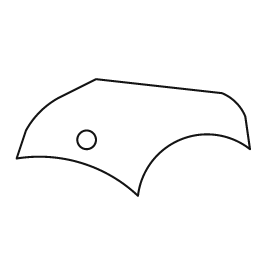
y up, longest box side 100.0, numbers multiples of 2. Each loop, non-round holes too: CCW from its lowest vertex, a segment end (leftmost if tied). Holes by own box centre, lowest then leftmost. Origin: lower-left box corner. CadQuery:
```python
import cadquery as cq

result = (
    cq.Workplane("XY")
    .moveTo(52.0, 0.0)
    .threePointArc((70.0, 24.0), (100.0, 20.0))
    .lineTo(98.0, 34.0)
    .threePointArc((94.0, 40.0), (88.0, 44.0))
    .lineTo(34.0, 50.0)
    .lineTo(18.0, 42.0)
    .threePointArc((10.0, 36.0), (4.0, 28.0))
    .lineTo(0.0, 16.0)
    .threePointArc((28.0, 14.0), (52.0, 0.0))
    .close()
    .moveTo(30.0, 24.0)
    .circle(4.0)
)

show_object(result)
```